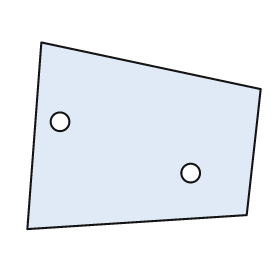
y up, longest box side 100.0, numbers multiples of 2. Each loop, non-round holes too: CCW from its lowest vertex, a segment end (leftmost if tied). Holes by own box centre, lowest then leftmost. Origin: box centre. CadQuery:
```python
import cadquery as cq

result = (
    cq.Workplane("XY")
    .moveTo(-50.0, -40.0)
    .lineTo(44.0, -34.0)
    .lineTo(50.0, 20.0)
    .lineTo(-44.0, 40.0)
    .close()
    .moveTo(20.0, -16.0)
    .circle(4.0)
    .moveTo(-36.0, 6.0)
    .circle(4.0)
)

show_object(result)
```